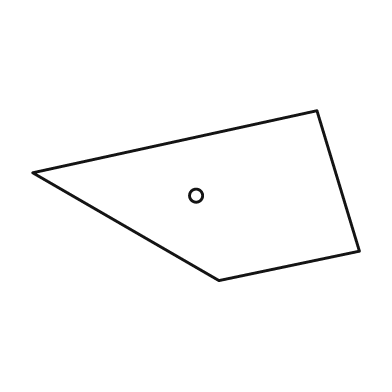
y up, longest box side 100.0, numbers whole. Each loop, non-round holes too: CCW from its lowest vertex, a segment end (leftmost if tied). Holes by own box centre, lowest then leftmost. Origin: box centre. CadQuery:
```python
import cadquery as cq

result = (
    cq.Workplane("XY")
    .moveTo(7.0, -26.0)
    .lineTo(50.0, -17.0)
    .lineTo(37.0, 26.0)
    .lineTo(-50.0, 7.0)
    .close()
    .moveTo(0.0, 0.0)
    .circle(2.0)
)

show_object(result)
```